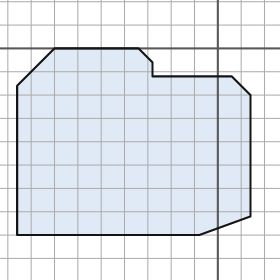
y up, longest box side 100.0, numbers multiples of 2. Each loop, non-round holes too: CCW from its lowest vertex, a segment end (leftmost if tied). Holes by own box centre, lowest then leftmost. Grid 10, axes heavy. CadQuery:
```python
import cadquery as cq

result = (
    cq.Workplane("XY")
    .moveTo(-86.0, -80.0)
    .lineTo(-8.0, -80.0)
    .lineTo(14.0, -72.0)
    .lineTo(14.0, -20.0)
    .lineTo(6.0, -12.0)
    .lineTo(-28.0, -12.0)
    .lineTo(-28.0, -6.0)
    .lineTo(-34.0, 0.0)
    .lineTo(-70.0, 0.0)
    .lineTo(-86.0, -16.0)
    .close()
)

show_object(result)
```